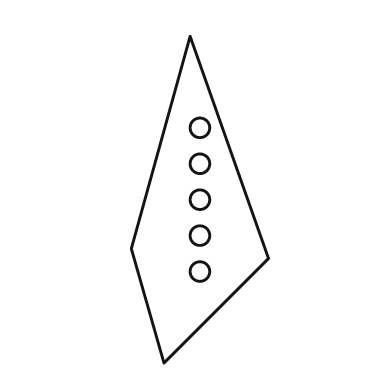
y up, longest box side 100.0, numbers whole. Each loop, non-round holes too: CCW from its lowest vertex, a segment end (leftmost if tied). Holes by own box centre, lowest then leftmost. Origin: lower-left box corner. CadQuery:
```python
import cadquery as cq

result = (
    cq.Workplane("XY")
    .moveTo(10.0, 0.0)
    .lineTo(42.0, 32.0)
    .lineTo(18.0, 100.0)
    .lineTo(0.0, 35.0)
    .close()
    .moveTo(21.0, 28.0)
    .circle(3.0)
    .moveTo(21.0, 39.0)
    .circle(3.0)
    .moveTo(21.0, 50.0)
    .circle(3.0)
    .moveTo(21.0, 61.0)
    .circle(3.0)
    .moveTo(21.0, 72.0)
    .circle(3.0)
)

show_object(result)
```